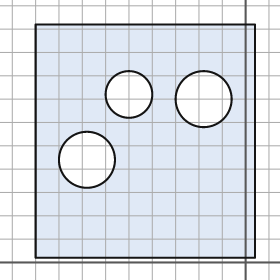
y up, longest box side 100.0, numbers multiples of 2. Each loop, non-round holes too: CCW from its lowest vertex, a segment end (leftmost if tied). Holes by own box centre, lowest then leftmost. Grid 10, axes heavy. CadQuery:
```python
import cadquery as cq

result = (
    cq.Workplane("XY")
    .moveTo(-90.0, 2.0)
    .lineTo(4.0, 2.0)
    .lineTo(4.0, 102.0)
    .lineTo(-90.0, 102.0)
    .close()
    .moveTo(-68.0, 44.0)
    .circle(12.0)
    .moveTo(-18.0, 70.0)
    .circle(12.0)
    .moveTo(-50.0, 72.0)
    .circle(10.0)
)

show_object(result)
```